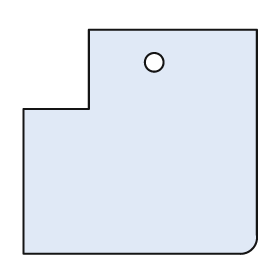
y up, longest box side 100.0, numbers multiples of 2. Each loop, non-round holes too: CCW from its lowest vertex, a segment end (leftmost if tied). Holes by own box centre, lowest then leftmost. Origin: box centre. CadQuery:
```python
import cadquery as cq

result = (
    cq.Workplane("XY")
    .moveTo(-50.0, -48.0)
    .lineTo(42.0, -48.0)
    .threePointArc((48.0, -46.0), (50.0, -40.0))
    .lineTo(50.0, 48.0)
    .lineTo(-22.0, 48.0)
    .lineTo(-22.0, 14.0)
    .lineTo(-50.0, 14.0)
    .close()
    .moveTo(6.0, 34.0)
    .circle(4.0)
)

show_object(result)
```